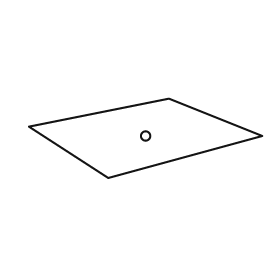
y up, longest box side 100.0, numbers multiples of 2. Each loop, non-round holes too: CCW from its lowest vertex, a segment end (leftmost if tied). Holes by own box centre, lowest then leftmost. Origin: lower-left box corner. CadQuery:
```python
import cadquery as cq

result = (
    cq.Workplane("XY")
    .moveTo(34.0, 0.0)
    .lineTo(100.0, 18.0)
    .lineTo(60.0, 34.0)
    .lineTo(0.0, 22.0)
    .close()
    .moveTo(50.0, 18.0)
    .circle(2.0)
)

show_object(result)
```